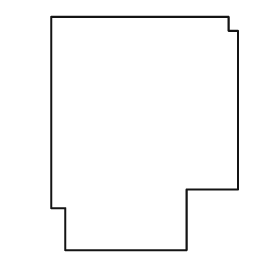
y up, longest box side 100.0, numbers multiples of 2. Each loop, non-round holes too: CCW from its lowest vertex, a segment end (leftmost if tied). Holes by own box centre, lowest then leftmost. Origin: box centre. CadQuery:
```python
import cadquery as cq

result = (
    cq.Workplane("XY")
    .moveTo(-34.0, -50.0)
    .lineTo(18.0, -50.0)
    .lineTo(18.0, -24.0)
    .lineTo(40.0, -24.0)
    .lineTo(40.0, 44.0)
    .lineTo(36.0, 44.0)
    .lineTo(36.0, 50.0)
    .lineTo(-40.0, 50.0)
    .lineTo(-40.0, -32.0)
    .lineTo(-34.0, -32.0)
    .close()
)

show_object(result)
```